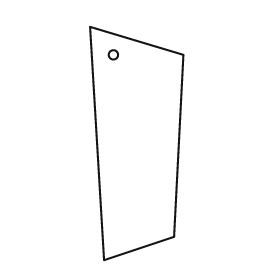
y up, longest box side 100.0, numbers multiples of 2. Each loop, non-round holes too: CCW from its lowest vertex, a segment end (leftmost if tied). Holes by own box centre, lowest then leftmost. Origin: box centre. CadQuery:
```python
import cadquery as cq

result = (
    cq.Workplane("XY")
    .moveTo(-14.0, -50.0)
    .lineTo(16.0, -40.0)
    .lineTo(20.0, 38.0)
    .lineTo(-20.0, 50.0)
    .close()
    .moveTo(-10.0, 38.0)
    .circle(2.0)
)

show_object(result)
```